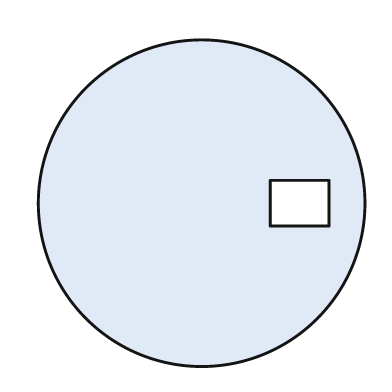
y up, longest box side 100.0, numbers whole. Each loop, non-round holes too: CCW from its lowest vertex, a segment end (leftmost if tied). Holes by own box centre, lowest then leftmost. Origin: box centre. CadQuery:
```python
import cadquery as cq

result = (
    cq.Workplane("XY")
    .moveTo(0.0, 0.0)
    .circle(50.0)
    .moveTo(21.0, -7.0)
    .lineTo(39.0, -7.0)
    .lineTo(39.0, 7.0)
    .lineTo(21.0, 7.0)
    .close()
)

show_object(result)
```